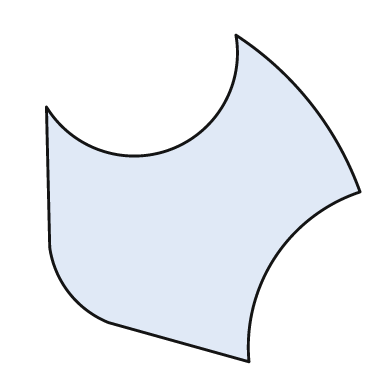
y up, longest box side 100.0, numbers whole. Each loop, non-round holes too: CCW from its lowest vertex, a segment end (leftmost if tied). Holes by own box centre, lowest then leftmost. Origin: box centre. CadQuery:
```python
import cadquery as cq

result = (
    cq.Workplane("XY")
    .moveTo(14.0, -50.0)
    .threePointArc((22.0, -18.0), (48.0, 2.0))
    .threePointArc((33.0, 29.0), (10.0, 50.0))
    .threePointArc((-10.0, 15.0), (-48.0, 28.0))
    .lineTo(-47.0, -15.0)
    .threePointArc((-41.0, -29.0), (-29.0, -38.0))
    .close()
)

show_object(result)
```